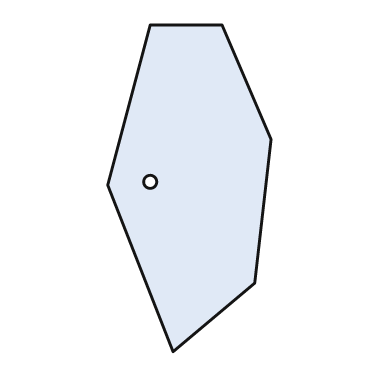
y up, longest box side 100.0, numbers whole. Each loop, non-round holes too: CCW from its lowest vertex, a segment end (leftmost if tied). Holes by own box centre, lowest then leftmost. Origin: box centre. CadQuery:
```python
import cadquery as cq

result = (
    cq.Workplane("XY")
    .moveTo(-5.0, -50.0)
    .lineTo(20.0, -29.0)
    .lineTo(25.0, 15.0)
    .lineTo(10.0, 50.0)
    .lineTo(-12.0, 50.0)
    .lineTo(-25.0, 1.0)
    .close()
    .moveTo(-12.0, 2.0)
    .circle(2.0)
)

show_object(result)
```